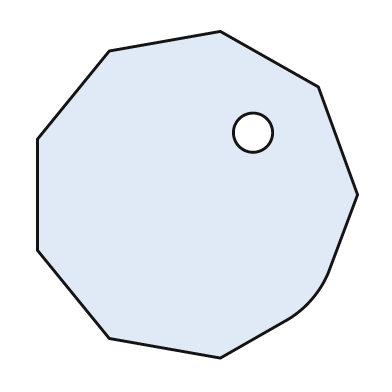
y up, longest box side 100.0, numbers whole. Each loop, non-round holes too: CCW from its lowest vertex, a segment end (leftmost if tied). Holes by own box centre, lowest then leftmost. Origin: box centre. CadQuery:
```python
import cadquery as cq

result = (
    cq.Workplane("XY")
    .moveTo(7.0, -50.0)
    .lineTo(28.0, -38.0)
    .threePointArc((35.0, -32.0), (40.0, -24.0))
    .lineTo(49.0, 0.0)
    .lineTo(37.0, 33.0)
    .lineTo(7.0, 50.0)
    .lineTo(-27.0, 44.0)
    .lineTo(-49.0, 17.0)
    .lineTo(-49.0, -17.0)
    .lineTo(-27.0, -44.0)
    .close()
    .moveTo(17.0, 19.0)
    .circle(6.0)
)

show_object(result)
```